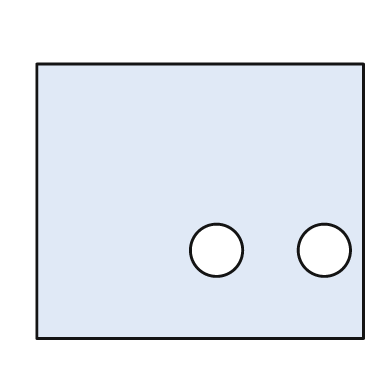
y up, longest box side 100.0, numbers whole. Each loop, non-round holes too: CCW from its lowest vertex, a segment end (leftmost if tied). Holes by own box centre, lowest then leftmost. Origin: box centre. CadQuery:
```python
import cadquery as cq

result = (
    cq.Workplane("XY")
    .moveTo(-50.0, -42.0)
    .lineTo(50.0, -42.0)
    .lineTo(50.0, 42.0)
    .lineTo(-50.0, 42.0)
    .close()
    .moveTo(5.0, -15.0)
    .circle(8.0)
    .moveTo(38.0, -15.0)
    .circle(8.0)
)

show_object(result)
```